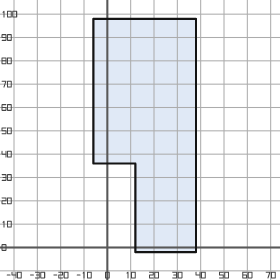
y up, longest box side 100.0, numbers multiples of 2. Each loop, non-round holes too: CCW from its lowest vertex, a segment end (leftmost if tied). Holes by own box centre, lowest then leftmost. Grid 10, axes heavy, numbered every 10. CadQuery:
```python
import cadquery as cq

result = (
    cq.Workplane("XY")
    .moveTo(12.0, -2.0)
    .lineTo(38.0, -2.0)
    .lineTo(38.0, 98.0)
    .lineTo(-6.0, 98.0)
    .lineTo(-6.0, 36.0)
    .lineTo(12.0, 36.0)
    .close()
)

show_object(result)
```